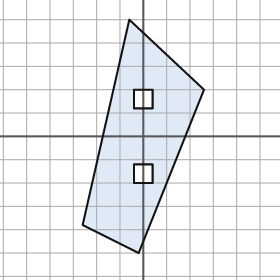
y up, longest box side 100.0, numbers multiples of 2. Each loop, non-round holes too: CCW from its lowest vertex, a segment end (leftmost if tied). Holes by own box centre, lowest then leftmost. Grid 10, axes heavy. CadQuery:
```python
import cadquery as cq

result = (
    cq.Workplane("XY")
    .moveTo(-2.0, -50.0)
    .lineTo(26.0, 20.0)
    .lineTo(-6.0, 50.0)
    .lineTo(-26.0, -38.0)
    .close()
    .moveTo(-4.0, -20.0)
    .lineTo(4.0, -20.0)
    .lineTo(4.0, -12.0)
    .lineTo(-4.0, -12.0)
    .close()
    .moveTo(-4.0, 12.0)
    .lineTo(4.0, 12.0)
    .lineTo(4.0, 20.0)
    .lineTo(-4.0, 20.0)
    .close()
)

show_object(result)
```